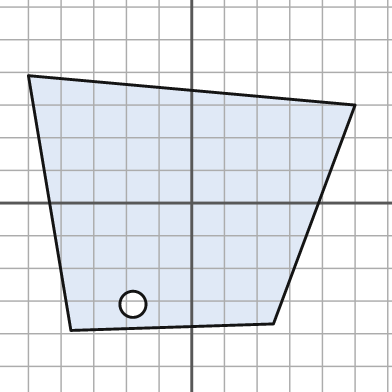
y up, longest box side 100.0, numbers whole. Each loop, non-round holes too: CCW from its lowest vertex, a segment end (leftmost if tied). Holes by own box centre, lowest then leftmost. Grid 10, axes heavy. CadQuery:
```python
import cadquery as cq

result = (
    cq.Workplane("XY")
    .moveTo(-37.0, -39.0)
    .lineTo(25.0, -37.0)
    .lineTo(50.0, 30.0)
    .lineTo(-50.0, 39.0)
    .close()
    .moveTo(-18.0, -31.0)
    .circle(4.0)
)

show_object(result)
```